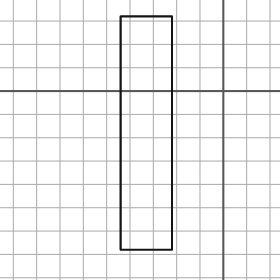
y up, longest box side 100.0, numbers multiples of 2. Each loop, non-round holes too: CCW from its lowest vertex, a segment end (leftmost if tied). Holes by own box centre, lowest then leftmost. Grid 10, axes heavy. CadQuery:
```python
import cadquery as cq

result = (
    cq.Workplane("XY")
    .moveTo(-44.0, -68.0)
    .lineTo(-22.0, -68.0)
    .lineTo(-22.0, 32.0)
    .lineTo(-44.0, 32.0)
    .close()
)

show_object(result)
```